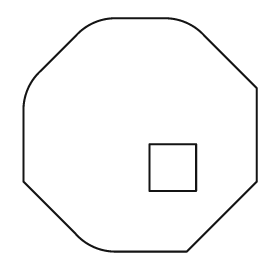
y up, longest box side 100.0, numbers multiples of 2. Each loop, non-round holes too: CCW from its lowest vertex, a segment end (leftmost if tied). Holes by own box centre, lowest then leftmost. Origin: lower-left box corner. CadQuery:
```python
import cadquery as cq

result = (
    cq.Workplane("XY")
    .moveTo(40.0, 0.0)
    .lineTo(70.0, 0.0)
    .lineTo(100.0, 30.0)
    .lineTo(100.0, 70.0)
    .lineTo(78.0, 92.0)
    .threePointArc((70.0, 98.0), (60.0, 100.0))
    .lineTo(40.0, 100.0)
    .threePointArc((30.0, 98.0), (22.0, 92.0))
    .lineTo(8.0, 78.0)
    .threePointArc((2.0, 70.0), (0.0, 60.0))
    .lineTo(0.0, 30.0)
    .lineTo(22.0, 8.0)
    .threePointArc((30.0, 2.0), (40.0, 0.0))
    .close()
    .moveTo(54.0, 26.0)
    .lineTo(74.0, 26.0)
    .lineTo(74.0, 46.0)
    .lineTo(54.0, 46.0)
    .close()
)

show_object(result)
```